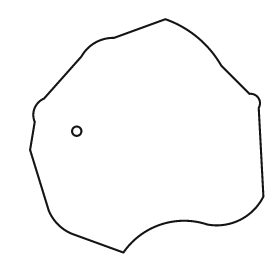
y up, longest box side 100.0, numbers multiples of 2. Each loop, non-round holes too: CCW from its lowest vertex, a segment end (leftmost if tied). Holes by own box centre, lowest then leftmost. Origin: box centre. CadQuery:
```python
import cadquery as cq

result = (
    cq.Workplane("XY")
    .moveTo(-10.0, -50.0)
    .threePointArc((6.0, -38.0), (26.0, -38.0))
    .threePointArc((40.0, -36.0), (50.0, -26.0))
    .lineTo(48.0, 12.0)
    .threePointArc((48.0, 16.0), (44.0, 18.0))
    .lineTo(32.0, 30.0)
    .threePointArc((22.0, 42.0), (8.0, 50.0))
    .lineTo(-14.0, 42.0)
    .threePointArc((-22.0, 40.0), (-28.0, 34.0))
    .lineTo(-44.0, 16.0)
    .threePointArc((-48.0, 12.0), (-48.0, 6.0))
    .lineTo(-50.0, -6.0)
    .lineTo(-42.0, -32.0)
    .threePointArc((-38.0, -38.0), (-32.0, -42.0))
    .close()
    .moveTo(-30.0, 2.0)
    .circle(2.0)
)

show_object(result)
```